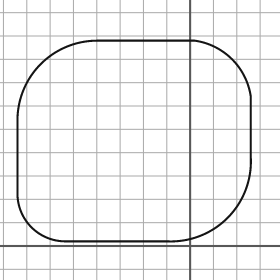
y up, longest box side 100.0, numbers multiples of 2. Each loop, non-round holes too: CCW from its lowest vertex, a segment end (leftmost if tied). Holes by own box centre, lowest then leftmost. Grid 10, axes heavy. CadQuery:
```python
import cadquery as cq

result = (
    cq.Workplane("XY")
    .moveTo(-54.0, 2.0)
    .lineTo(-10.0, 2.0)
    .threePointArc((16.0, 12.0), (26.0, 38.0))
    .lineTo(26.0, 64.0)
    .threePointArc((18.0, 80.0), (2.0, 88.0))
    .lineTo(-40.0, 88.0)
    .threePointArc((-64.0, 78.0), (-74.0, 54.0))
    .lineTo(-74.0, 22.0)
    .threePointArc((-68.0, 8.0), (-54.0, 2.0))
    .close()
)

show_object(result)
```